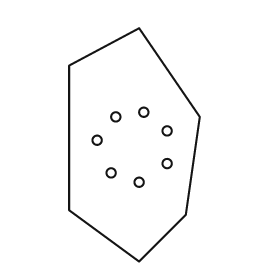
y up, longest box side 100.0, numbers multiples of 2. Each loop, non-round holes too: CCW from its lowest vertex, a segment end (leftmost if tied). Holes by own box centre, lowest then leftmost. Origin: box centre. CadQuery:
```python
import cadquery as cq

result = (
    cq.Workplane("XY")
    .moveTo(2.0, -50.0)
    .lineTo(22.0, -30.0)
    .lineTo(28.0, 12.0)
    .lineTo(2.0, 50.0)
    .lineTo(-28.0, 34.0)
    .lineTo(-28.0, -28.0)
    .close()
    .moveTo(2.0, -16.0)
    .circle(2.0)
    .moveTo(-10.0, -12.0)
    .circle(2.0)
    .moveTo(14.0, -8.0)
    .circle(2.0)
    .moveTo(-16.0, 2.0)
    .circle(2.0)
    .moveTo(14.0, 6.0)
    .circle(2.0)
    .moveTo(-8.0, 12.0)
    .circle(2.0)
    .moveTo(4.0, 14.0)
    .circle(2.0)
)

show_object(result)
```